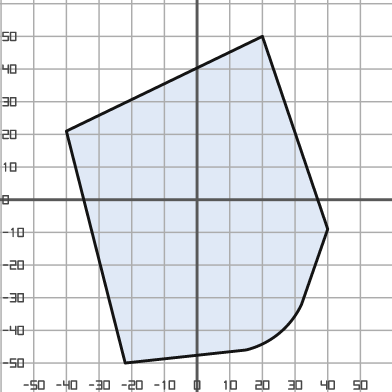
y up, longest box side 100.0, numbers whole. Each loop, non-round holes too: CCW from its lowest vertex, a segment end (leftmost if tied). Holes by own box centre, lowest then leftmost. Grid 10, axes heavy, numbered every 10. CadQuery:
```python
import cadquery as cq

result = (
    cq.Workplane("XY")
    .moveTo(-22.0, -50.0)
    .lineTo(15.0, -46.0)
    .threePointArc((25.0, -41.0), (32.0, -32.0))
    .lineTo(40.0, -9.0)
    .lineTo(20.0, 50.0)
    .lineTo(-40.0, 21.0)
    .close()
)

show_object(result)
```